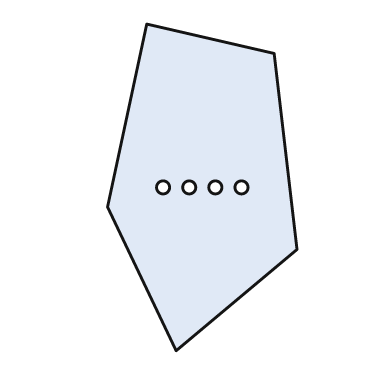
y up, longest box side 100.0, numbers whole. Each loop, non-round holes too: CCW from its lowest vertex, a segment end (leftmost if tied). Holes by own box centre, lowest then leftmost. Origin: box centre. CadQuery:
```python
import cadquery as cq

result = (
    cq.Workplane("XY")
    .moveTo(-8.0, -50.0)
    .lineTo(29.0, -19.0)
    .lineTo(22.0, 41.0)
    .lineTo(-17.0, 50.0)
    .lineTo(-29.0, -6.0)
    .close()
    .moveTo(-12.0, 0.0)
    .circle(2.0)
    .moveTo(-4.0, 0.0)
    .circle(2.0)
    .moveTo(4.0, 0.0)
    .circle(2.0)
    .moveTo(12.0, 0.0)
    .circle(2.0)
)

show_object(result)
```